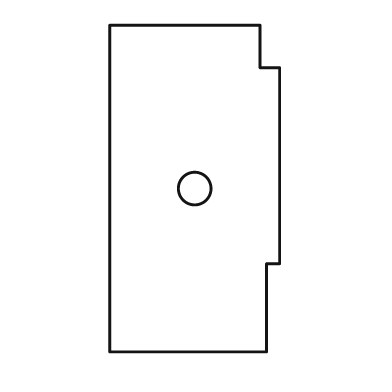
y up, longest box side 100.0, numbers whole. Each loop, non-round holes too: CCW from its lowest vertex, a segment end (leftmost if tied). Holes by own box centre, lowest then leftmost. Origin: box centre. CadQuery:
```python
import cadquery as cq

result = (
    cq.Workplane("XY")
    .moveTo(-26.0, -50.0)
    .lineTo(22.0, -50.0)
    .lineTo(22.0, -23.0)
    .lineTo(26.0, -23.0)
    .lineTo(26.0, 37.0)
    .lineTo(20.0, 37.0)
    .lineTo(20.0, 50.0)
    .lineTo(-26.0, 50.0)
    .close()
    .moveTo(0.0, 0.0)
    .circle(5.0)
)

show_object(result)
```